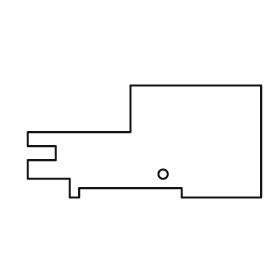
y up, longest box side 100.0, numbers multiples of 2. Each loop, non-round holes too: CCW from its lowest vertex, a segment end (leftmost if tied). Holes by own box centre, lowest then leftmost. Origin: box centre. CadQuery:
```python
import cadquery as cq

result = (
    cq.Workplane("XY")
    .moveTo(-32.0, -24.0)
    .lineTo(-28.0, -24.0)
    .lineTo(-28.0, -20.0)
    .lineTo(16.0, -20.0)
    .lineTo(16.0, -24.0)
    .lineTo(50.0, -24.0)
    .lineTo(50.0, 24.0)
    .lineTo(-6.0, 24.0)
    .lineTo(-6.0, 4.0)
    .lineTo(-50.0, 4.0)
    .lineTo(-50.0, -2.0)
    .lineTo(-38.0, -2.0)
    .lineTo(-38.0, -8.0)
    .lineTo(-50.0, -8.0)
    .lineTo(-50.0, -16.0)
    .lineTo(-32.0, -16.0)
    .close()
    .moveTo(8.0, -14.0)
    .circle(2.0)
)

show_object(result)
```